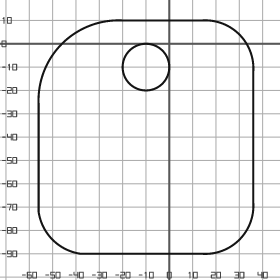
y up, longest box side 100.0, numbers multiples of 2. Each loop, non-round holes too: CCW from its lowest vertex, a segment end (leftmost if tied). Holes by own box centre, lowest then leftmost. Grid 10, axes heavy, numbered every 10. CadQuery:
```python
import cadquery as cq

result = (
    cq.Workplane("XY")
    .moveTo(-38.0, -90.0)
    .lineTo(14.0, -90.0)
    .threePointArc((30.0, -84.0), (36.0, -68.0))
    .lineTo(36.0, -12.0)
    .threePointArc((30.0, 4.0), (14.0, 10.0))
    .lineTo(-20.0, 10.0)
    .threePointArc((-46.0, 0.0), (-56.0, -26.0))
    .lineTo(-56.0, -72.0)
    .threePointArc((-50.0, -84.0), (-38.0, -90.0))
    .close()
    .moveTo(-10.0, -10.0)
    .circle(10.0)
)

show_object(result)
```